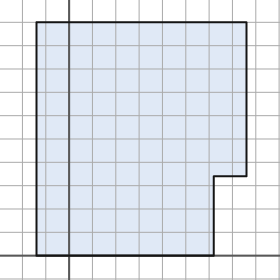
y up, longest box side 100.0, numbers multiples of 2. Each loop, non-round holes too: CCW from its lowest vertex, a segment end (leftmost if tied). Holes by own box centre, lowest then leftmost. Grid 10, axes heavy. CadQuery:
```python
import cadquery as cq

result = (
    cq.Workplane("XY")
    .moveTo(-14.0, 0.0)
    .lineTo(62.0, 0.0)
    .lineTo(62.0, 34.0)
    .lineTo(76.0, 34.0)
    .lineTo(76.0, 100.0)
    .lineTo(-14.0, 100.0)
    .close()
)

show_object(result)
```